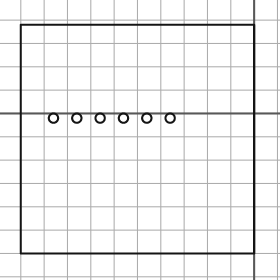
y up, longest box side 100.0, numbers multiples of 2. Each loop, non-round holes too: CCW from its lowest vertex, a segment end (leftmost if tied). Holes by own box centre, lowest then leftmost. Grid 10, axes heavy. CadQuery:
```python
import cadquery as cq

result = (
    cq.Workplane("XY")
    .moveTo(-100.0, -60.0)
    .lineTo(0.0, -60.0)
    .lineTo(0.0, 38.0)
    .lineTo(-100.0, 38.0)
    .close()
    .moveTo(-86.0, -2.0)
    .circle(2.0)
    .moveTo(-76.0, -2.0)
    .circle(2.0)
    .moveTo(-66.0, -2.0)
    .circle(2.0)
    .moveTo(-56.0, -2.0)
    .circle(2.0)
    .moveTo(-46.0, -2.0)
    .circle(2.0)
    .moveTo(-36.0, -2.0)
    .circle(2.0)
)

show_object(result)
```